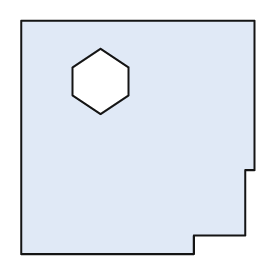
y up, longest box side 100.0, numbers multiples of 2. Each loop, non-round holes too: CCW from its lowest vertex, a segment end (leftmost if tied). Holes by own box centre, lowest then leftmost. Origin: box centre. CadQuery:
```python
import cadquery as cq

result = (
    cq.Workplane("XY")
    .moveTo(-50.0, -50.0)
    .lineTo(24.0, -50.0)
    .lineTo(24.0, -42.0)
    .lineTo(46.0, -42.0)
    .lineTo(46.0, -14.0)
    .lineTo(50.0, -14.0)
    .lineTo(50.0, 50.0)
    .lineTo(-50.0, 50.0)
    .close()
    .moveTo(-16.0, 10.0)
    .lineTo(-4.0, 18.0)
    .lineTo(-4.0, 30.0)
    .lineTo(-16.0, 38.0)
    .lineTo(-28.0, 30.0)
    .lineTo(-28.0, 18.0)
    .close()
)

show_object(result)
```